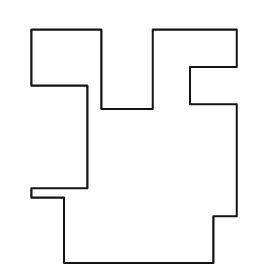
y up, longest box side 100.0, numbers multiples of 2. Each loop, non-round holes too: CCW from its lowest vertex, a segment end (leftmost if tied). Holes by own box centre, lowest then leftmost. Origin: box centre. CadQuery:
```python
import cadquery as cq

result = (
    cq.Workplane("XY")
    .moveTo(-30.0, -50.0)
    .lineTo(34.0, -50.0)
    .lineTo(34.0, -30.0)
    .lineTo(44.0, -30.0)
    .lineTo(44.0, 18.0)
    .lineTo(24.0, 18.0)
    .lineTo(24.0, 34.0)
    .lineTo(44.0, 34.0)
    .lineTo(44.0, 50.0)
    .lineTo(8.0, 50.0)
    .lineTo(8.0, 16.0)
    .lineTo(-14.0, 16.0)
    .lineTo(-14.0, 50.0)
    .lineTo(-44.0, 50.0)
    .lineTo(-44.0, 26.0)
    .lineTo(-20.0, 26.0)
    .lineTo(-20.0, -18.0)
    .lineTo(-44.0, -18.0)
    .lineTo(-44.0, -22.0)
    .lineTo(-30.0, -22.0)
    .close()
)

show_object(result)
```